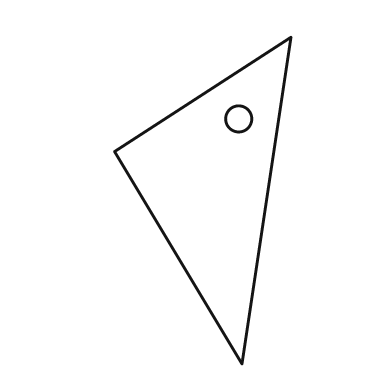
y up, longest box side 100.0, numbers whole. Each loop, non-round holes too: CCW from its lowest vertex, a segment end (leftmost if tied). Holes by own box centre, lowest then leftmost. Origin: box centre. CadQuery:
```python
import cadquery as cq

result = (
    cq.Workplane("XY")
    .moveTo(12.0, -50.0)
    .lineTo(27.0, 50.0)
    .lineTo(-27.0, 15.0)
    .close()
    .moveTo(11.0, 25.0)
    .circle(4.0)
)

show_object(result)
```